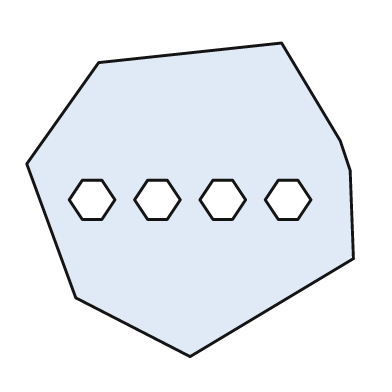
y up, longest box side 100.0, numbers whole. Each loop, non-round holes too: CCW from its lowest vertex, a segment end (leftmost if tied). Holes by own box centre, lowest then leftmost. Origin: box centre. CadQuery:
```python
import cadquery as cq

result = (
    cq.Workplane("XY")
    .moveTo(0.0, -48.0)
    .lineTo(50.0, -18.0)
    .lineTo(49.0, 9.0)
    .lineTo(46.0, 18.0)
    .lineTo(28.0, 48.0)
    .lineTo(-28.0, 42.0)
    .lineTo(-50.0, 11.0)
    .lineTo(-35.0, -30.0)
    .close()
    .moveTo(-33.0, -6.0)
    .lineTo(-27.0, -6.0)
    .lineTo(-23.0, 0.0)
    .lineTo(-27.0, 6.0)
    .lineTo(-33.0, 6.0)
    .lineTo(-37.0, 0.0)
    .close()
    .moveTo(-13.0, -6.0)
    .lineTo(-7.0, -6.0)
    .lineTo(-3.0, 0.0)
    .lineTo(-7.0, 6.0)
    .lineTo(-13.0, 6.0)
    .lineTo(-17.0, 0.0)
    .close()
    .moveTo(7.0, -6.0)
    .lineTo(13.0, -6.0)
    .lineTo(17.0, 0.0)
    .lineTo(13.0, 6.0)
    .lineTo(7.0, 6.0)
    .lineTo(3.0, 0.0)
    .close()
    .moveTo(27.0, -6.0)
    .lineTo(33.0, -6.0)
    .lineTo(37.0, 0.0)
    .lineTo(33.0, 6.0)
    .lineTo(27.0, 6.0)
    .lineTo(23.0, 0.0)
    .close()
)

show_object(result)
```